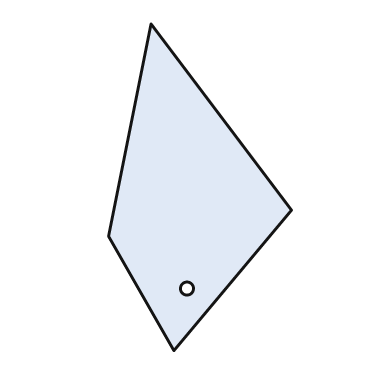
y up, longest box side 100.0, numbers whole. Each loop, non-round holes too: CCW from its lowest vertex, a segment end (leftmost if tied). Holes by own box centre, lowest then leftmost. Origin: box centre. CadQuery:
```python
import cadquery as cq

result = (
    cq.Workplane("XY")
    .moveTo(-8.0, -50.0)
    .lineTo(28.0, -7.0)
    .lineTo(-15.0, 50.0)
    .lineTo(-28.0, -15.0)
    .close()
    .moveTo(-4.0, -31.0)
    .circle(2.0)
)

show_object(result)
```